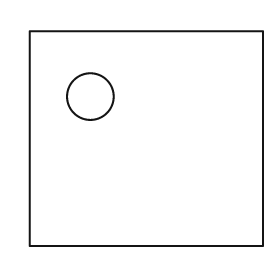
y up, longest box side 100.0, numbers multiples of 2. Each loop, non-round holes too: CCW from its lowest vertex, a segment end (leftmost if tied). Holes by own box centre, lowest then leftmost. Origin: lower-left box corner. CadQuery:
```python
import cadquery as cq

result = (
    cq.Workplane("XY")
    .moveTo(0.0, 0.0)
    .lineTo(100.0, 0.0)
    .lineTo(100.0, 92.0)
    .lineTo(0.0, 92.0)
    .close()
    .moveTo(26.0, 64.0)
    .circle(10.0)
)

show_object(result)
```